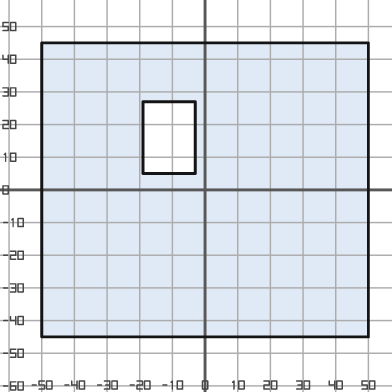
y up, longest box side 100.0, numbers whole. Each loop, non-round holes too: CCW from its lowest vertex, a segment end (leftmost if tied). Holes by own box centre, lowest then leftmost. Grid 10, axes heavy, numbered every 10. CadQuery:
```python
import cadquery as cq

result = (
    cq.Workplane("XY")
    .moveTo(-50.0, -45.0)
    .lineTo(50.0, -45.0)
    .lineTo(50.0, 45.0)
    .lineTo(-50.0, 45.0)
    .close()
    .moveTo(-19.0, 5.0)
    .lineTo(-3.0, 5.0)
    .lineTo(-3.0, 27.0)
    .lineTo(-19.0, 27.0)
    .close()
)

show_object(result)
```